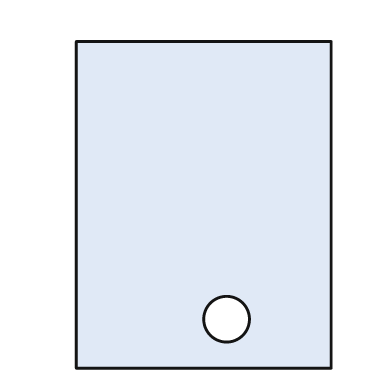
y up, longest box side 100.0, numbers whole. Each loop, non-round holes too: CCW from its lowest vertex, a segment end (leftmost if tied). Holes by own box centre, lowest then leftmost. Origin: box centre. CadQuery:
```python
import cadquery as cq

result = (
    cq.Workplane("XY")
    .moveTo(-39.0, -50.0)
    .lineTo(39.0, -50.0)
    .lineTo(39.0, 50.0)
    .lineTo(-39.0, 50.0)
    .close()
    .moveTo(7.0, -35.0)
    .circle(7.0)
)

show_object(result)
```